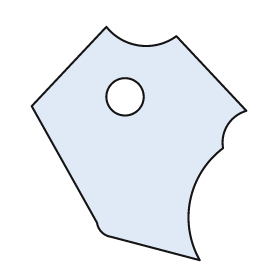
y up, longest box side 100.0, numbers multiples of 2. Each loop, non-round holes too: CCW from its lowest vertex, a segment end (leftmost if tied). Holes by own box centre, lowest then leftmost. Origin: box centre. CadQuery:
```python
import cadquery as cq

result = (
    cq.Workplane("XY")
    .moveTo(26.0, -50.0)
    .threePointArc((22.0, -24.0), (36.0, -2.0))
    .threePointArc((38.0, 8.0), (46.0, 14.0))
    .lineTo(16.0, 46.0)
    .threePointArc((0.0, 42.0), (-14.0, 50.0))
    .lineTo(-46.0, 16.0)
    .lineTo(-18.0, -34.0)
    .threePointArc((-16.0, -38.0), (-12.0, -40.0))
    .close()
    .moveTo(-6.0, 20.0)
    .circle(8.0)
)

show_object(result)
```